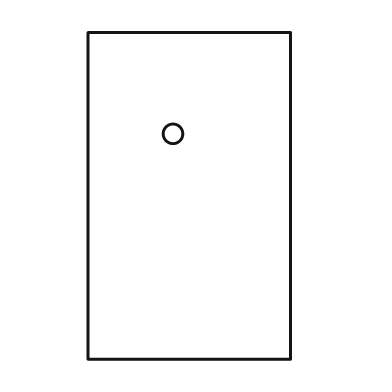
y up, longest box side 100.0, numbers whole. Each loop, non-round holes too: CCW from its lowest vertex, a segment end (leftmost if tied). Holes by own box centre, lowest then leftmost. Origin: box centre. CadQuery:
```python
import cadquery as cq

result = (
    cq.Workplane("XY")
    .moveTo(-31.0, -50.0)
    .lineTo(31.0, -50.0)
    .lineTo(31.0, 50.0)
    .lineTo(-31.0, 50.0)
    .close()
    .moveTo(-5.0, 19.0)
    .circle(3.0)
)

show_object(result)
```